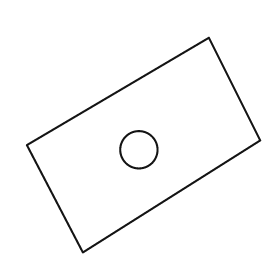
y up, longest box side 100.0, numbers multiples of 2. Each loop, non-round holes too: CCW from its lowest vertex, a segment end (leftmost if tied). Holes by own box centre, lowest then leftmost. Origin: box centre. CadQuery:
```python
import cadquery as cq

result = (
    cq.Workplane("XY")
    .moveTo(-26.0, -46.0)
    .lineTo(50.0, 2.0)
    .lineTo(28.0, 46.0)
    .lineTo(-50.0, 0.0)
    .close()
    .moveTo(-2.0, -2.0)
    .circle(8.0)
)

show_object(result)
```